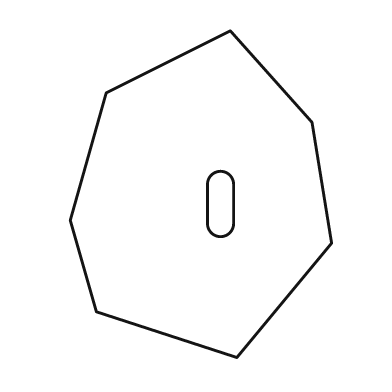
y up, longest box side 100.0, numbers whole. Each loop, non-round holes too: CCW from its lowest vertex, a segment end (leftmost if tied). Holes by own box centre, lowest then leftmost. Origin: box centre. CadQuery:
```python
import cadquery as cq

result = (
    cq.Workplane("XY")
    .moveTo(11.0, -50.0)
    .lineTo(40.0, -15.0)
    .lineTo(34.0, 22.0)
    .lineTo(9.0, 50.0)
    .lineTo(-29.0, 31.0)
    .lineTo(-40.0, -8.0)
    .lineTo(-32.0, -36.0)
    .close()
    .moveTo(2.0, -9.0)
    .threePointArc((6.0, -13.0), (10.0, -9.0))
    .lineTo(10.0, 3.0)
    .threePointArc((6.0, 7.0), (2.0, 3.0))
    .close()
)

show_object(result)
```